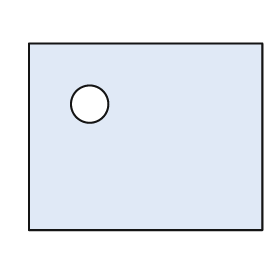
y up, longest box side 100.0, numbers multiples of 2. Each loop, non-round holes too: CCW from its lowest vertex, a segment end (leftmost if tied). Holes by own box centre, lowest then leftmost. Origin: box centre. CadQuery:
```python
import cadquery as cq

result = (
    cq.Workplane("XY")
    .moveTo(-50.0, -40.0)
    .lineTo(50.0, -40.0)
    .lineTo(50.0, 40.0)
    .lineTo(-50.0, 40.0)
    .close()
    .moveTo(-24.0, 14.0)
    .circle(8.0)
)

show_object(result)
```